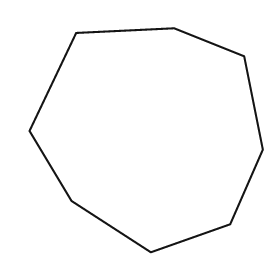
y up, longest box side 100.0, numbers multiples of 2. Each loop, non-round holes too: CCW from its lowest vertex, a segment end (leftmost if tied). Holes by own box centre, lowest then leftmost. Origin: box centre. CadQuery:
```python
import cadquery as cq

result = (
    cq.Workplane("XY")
    .moveTo(2.0, -48.0)
    .lineTo(36.0, -36.0)
    .lineTo(50.0, -4.0)
    .lineTo(42.0, 36.0)
    .lineTo(12.0, 48.0)
    .lineTo(-30.0, 46.0)
    .lineTo(-50.0, 4.0)
    .lineTo(-32.0, -26.0)
    .close()
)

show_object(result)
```